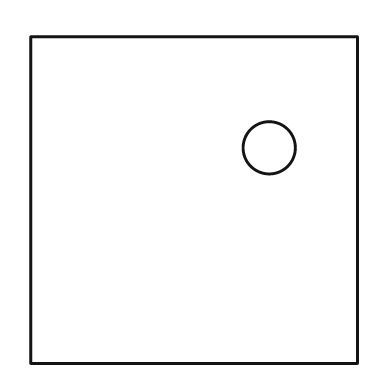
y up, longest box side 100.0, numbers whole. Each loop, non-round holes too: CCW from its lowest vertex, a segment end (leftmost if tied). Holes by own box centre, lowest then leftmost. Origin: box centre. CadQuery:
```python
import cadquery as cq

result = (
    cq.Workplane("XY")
    .moveTo(-50.0, -50.0)
    .lineTo(50.0, -50.0)
    .lineTo(50.0, 50.0)
    .lineTo(-50.0, 50.0)
    .close()
    .moveTo(23.0, 16.0)
    .circle(8.0)
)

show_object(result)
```